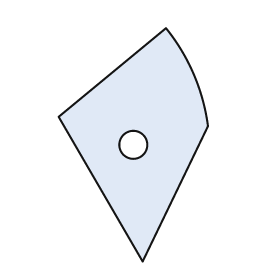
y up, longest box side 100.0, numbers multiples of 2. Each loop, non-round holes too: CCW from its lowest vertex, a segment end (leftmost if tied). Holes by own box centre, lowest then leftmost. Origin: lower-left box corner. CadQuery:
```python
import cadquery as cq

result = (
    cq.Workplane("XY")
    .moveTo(36.0, 0.0)
    .lineTo(64.0, 58.0)
    .threePointArc((58.0, 80.0), (46.0, 100.0))
    .lineTo(0.0, 62.0)
    .close()
    .moveTo(32.0, 50.0)
    .circle(6.0)
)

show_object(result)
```